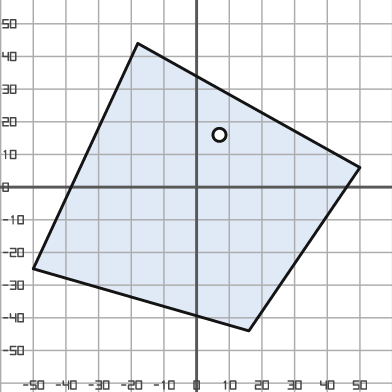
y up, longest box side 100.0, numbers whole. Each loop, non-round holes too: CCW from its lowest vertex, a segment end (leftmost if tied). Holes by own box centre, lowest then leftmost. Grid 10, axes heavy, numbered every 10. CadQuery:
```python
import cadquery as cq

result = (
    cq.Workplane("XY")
    .moveTo(16.0, -44.0)
    .lineTo(50.0, 6.0)
    .lineTo(-18.0, 44.0)
    .lineTo(-50.0, -25.0)
    .close()
    .moveTo(7.0, 16.0)
    .circle(2.0)
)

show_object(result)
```